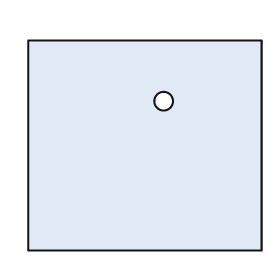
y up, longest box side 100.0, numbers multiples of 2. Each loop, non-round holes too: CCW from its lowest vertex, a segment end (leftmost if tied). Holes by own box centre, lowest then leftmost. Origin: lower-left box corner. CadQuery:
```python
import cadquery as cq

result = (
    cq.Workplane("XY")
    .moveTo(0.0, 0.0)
    .lineTo(100.0, 0.0)
    .lineTo(100.0, 90.0)
    .lineTo(0.0, 90.0)
    .close()
    .moveTo(58.0, 64.0)
    .circle(4.0)
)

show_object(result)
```